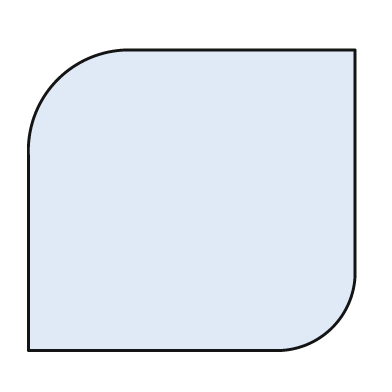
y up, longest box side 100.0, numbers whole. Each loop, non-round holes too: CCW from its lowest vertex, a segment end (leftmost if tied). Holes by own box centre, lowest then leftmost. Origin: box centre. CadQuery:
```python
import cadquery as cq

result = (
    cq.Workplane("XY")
    .moveTo(-50.0, -46.0)
    .lineTo(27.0, -46.0)
    .threePointArc((43.0, -39.0), (50.0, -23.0))
    .lineTo(50.0, 46.0)
    .lineTo(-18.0, 46.0)
    .threePointArc((-41.0, 37.0), (-50.0, 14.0))
    .close()
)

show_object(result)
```